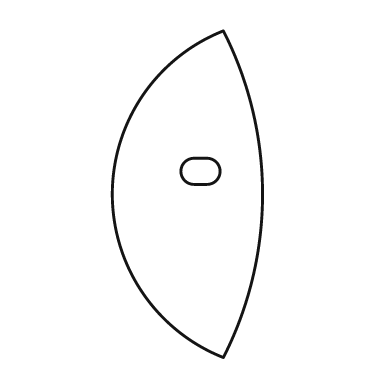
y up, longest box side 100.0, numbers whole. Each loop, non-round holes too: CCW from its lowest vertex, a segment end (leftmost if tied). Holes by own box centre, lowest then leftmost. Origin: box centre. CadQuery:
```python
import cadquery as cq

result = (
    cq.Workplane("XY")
    .moveTo(11.0, -50.0)
    .threePointArc((23.0, 0.0), (11.0, 50.0))
    .threePointArc((-23.0, 0.0), (11.0, -50.0))
    .close()
    .moveTo(2.0, 3.0)
    .lineTo(6.0, 3.0)
    .threePointArc((10.0, 7.0), (6.0, 11.0))
    .lineTo(2.0, 11.0)
    .threePointArc((-2.0, 7.0), (2.0, 3.0))
    .close()
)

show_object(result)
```